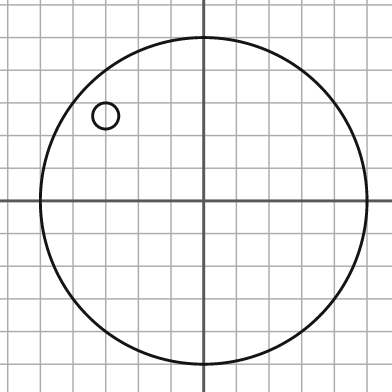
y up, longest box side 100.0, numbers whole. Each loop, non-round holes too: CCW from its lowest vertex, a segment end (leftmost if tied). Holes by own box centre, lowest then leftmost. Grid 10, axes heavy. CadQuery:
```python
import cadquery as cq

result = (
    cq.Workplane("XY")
    .moveTo(0.0, 0.0)
    .circle(50.0)
    .moveTo(-30.0, 26.0)
    .circle(4.0)
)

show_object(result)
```